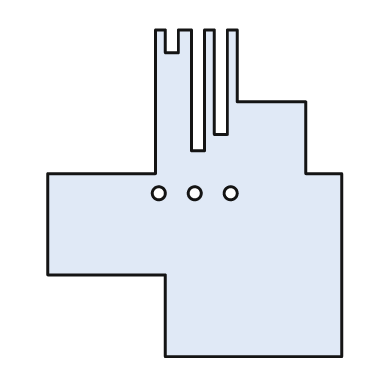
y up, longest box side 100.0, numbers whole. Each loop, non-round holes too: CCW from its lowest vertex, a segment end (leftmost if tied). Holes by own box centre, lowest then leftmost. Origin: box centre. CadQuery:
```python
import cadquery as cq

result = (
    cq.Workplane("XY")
    .moveTo(-9.0, -50.0)
    .lineTo(45.0, -50.0)
    .lineTo(45.0, 6.0)
    .lineTo(34.0, 6.0)
    .lineTo(34.0, 28.0)
    .lineTo(13.0, 28.0)
    .lineTo(13.0, 50.0)
    .lineTo(10.0, 50.0)
    .lineTo(10.0, 18.0)
    .lineTo(6.0, 18.0)
    .lineTo(6.0, 50.0)
    .lineTo(3.0, 50.0)
    .lineTo(3.0, 13.0)
    .lineTo(-1.0, 13.0)
    .lineTo(-1.0, 50.0)
    .lineTo(-5.0, 50.0)
    .lineTo(-5.0, 43.0)
    .lineTo(-9.0, 43.0)
    .lineTo(-9.0, 50.0)
    .lineTo(-12.0, 50.0)
    .lineTo(-12.0, 6.0)
    .lineTo(-45.0, 6.0)
    .lineTo(-45.0, -25.0)
    .lineTo(-9.0, -25.0)
    .close()
    .moveTo(-11.0, 0.0)
    .circle(2.0)
    .moveTo(0.0, 0.0)
    .circle(2.0)
    .moveTo(11.0, 0.0)
    .circle(2.0)
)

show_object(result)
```